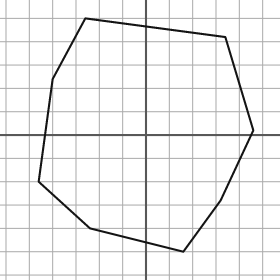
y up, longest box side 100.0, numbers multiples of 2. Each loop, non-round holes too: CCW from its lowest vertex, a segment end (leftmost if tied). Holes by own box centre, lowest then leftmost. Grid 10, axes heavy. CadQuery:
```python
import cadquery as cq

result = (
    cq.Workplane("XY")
    .moveTo(16.0, -50.0)
    .lineTo(32.0, -28.0)
    .lineTo(46.0, 2.0)
    .lineTo(34.0, 42.0)
    .lineTo(-26.0, 50.0)
    .lineTo(-40.0, 24.0)
    .lineTo(-46.0, -20.0)
    .lineTo(-24.0, -40.0)
    .close()
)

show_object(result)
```